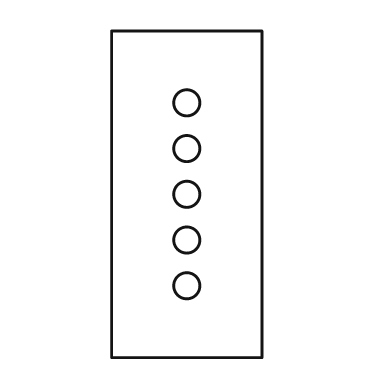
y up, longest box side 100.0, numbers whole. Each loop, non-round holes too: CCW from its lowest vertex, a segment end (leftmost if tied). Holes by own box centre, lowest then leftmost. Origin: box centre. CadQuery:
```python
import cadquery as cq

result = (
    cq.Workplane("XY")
    .moveTo(-23.0, -50.0)
    .lineTo(23.0, -50.0)
    .lineTo(23.0, 50.0)
    .lineTo(-23.0, 50.0)
    .close()
    .moveTo(0.0, -28.0)
    .circle(4.0)
    .moveTo(0.0, -14.0)
    .circle(4.0)
    .moveTo(0.0, 0.0)
    .circle(4.0)
    .moveTo(0.0, 14.0)
    .circle(4.0)
    .moveTo(0.0, 28.0)
    .circle(4.0)
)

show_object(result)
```